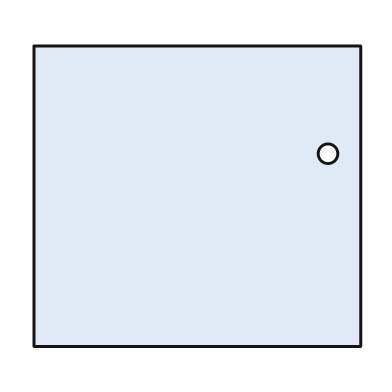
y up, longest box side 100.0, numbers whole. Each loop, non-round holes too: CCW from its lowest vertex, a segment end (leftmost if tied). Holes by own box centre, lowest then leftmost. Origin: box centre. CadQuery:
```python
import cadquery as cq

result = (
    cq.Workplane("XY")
    .moveTo(-50.0, -46.0)
    .lineTo(50.0, -46.0)
    .lineTo(50.0, 46.0)
    .lineTo(-50.0, 46.0)
    .close()
    .moveTo(40.0, 13.0)
    .circle(3.0)
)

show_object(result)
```